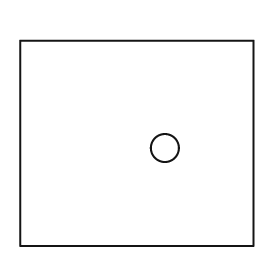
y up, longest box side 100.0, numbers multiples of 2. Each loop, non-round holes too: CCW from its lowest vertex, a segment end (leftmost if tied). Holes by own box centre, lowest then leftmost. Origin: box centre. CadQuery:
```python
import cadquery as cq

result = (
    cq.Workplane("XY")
    .moveTo(-50.0, -44.0)
    .lineTo(50.0, -44.0)
    .lineTo(50.0, 44.0)
    .lineTo(-50.0, 44.0)
    .close()
    .moveTo(12.0, -2.0)
    .circle(6.0)
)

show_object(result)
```